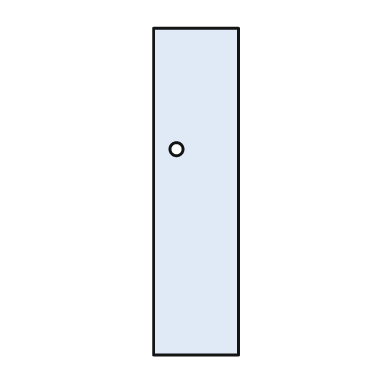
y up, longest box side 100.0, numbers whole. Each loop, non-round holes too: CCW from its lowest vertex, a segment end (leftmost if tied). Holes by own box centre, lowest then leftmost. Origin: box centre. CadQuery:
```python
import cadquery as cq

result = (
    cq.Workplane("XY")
    .moveTo(-13.0, -50.0)
    .lineTo(13.0, -50.0)
    .lineTo(13.0, 50.0)
    .lineTo(-13.0, 50.0)
    .close()
    .moveTo(-6.0, 13.0)
    .circle(2.0)
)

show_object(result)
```